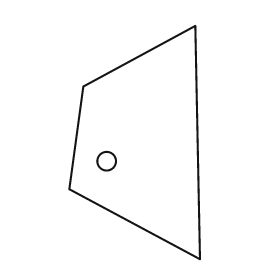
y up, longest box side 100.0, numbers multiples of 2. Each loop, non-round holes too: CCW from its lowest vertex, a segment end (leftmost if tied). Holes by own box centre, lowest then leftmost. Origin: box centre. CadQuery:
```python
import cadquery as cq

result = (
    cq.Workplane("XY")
    .moveTo(28.0, -50.0)
    .lineTo(26.0, 50.0)
    .lineTo(-22.0, 24.0)
    .lineTo(-28.0, -20.0)
    .close()
    .moveTo(-12.0, -8.0)
    .circle(4.0)
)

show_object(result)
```